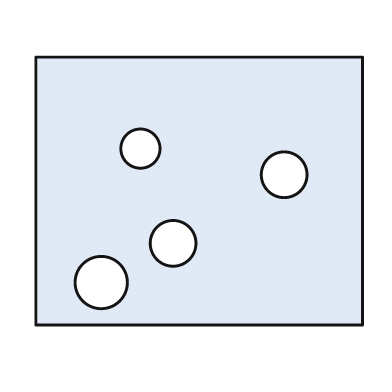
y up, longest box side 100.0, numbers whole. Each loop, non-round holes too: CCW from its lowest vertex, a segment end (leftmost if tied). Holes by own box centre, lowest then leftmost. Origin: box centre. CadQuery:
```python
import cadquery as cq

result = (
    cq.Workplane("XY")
    .moveTo(-50.0, -41.0)
    .lineTo(50.0, -41.0)
    .lineTo(50.0, 41.0)
    .lineTo(-50.0, 41.0)
    .close()
    .moveTo(-30.0, -28.0)
    .circle(8.0)
    .moveTo(-8.0, -16.0)
    .circle(7.0)
    .moveTo(26.0, 5.0)
    .circle(7.0)
    .moveTo(-18.0, 13.0)
    .circle(6.0)
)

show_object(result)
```